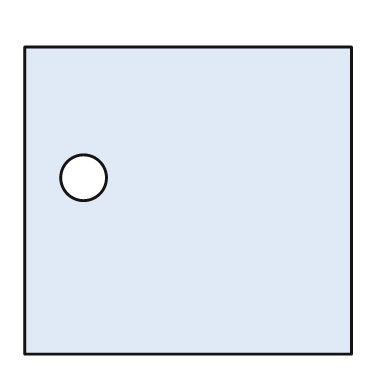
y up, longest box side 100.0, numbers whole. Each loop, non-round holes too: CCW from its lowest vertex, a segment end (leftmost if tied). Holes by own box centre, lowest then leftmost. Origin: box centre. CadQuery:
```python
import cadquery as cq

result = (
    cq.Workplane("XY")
    .moveTo(-50.0, -47.0)
    .lineTo(50.0, -47.0)
    .lineTo(50.0, 47.0)
    .lineTo(-50.0, 47.0)
    .close()
    .moveTo(-32.0, 7.0)
    .circle(7.0)
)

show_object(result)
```